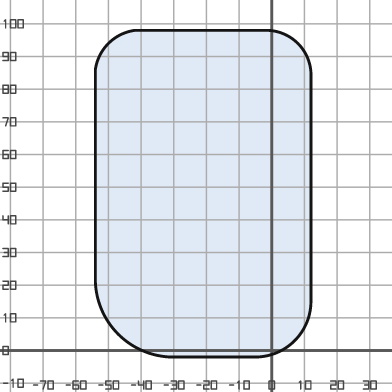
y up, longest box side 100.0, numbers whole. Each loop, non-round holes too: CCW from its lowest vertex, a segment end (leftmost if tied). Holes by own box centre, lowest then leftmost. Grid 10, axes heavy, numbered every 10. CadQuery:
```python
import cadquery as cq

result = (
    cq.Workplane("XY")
    .moveTo(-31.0, -2.0)
    .lineTo(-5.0, -2.0)
    .threePointArc((7.0, 3.0), (12.0, 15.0))
    .lineTo(12.0, 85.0)
    .threePointArc((8.0, 94.0), (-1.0, 98.0))
    .lineTo(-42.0, 98.0)
    .threePointArc((-50.0, 94.0), (-54.0, 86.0))
    .lineTo(-54.0, 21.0)
    .threePointArc((-47.0, 5.0), (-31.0, -2.0))
    .close()
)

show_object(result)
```